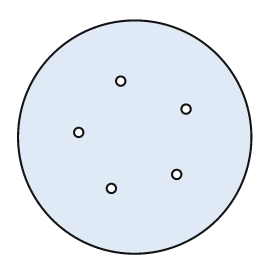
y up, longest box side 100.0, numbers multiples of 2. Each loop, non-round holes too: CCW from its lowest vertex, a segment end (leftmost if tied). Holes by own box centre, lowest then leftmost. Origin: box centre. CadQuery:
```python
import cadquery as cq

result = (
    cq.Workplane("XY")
    .moveTo(0.0, 0.0)
    .circle(50.0)
    .moveTo(-10.0, -22.0)
    .circle(2.0)
    .moveTo(18.0, -16.0)
    .circle(2.0)
    .moveTo(-24.0, 2.0)
    .circle(2.0)
    .moveTo(22.0, 12.0)
    .circle(2.0)
    .moveTo(-6.0, 24.0)
    .circle(2.0)
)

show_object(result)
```